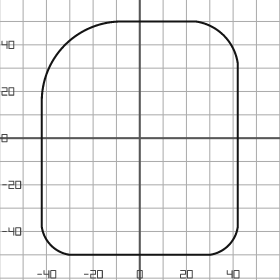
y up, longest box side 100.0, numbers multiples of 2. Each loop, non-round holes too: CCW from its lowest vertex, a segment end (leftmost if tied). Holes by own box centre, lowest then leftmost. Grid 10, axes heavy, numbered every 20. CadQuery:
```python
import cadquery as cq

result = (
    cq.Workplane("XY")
    .moveTo(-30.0, -50.0)
    .lineTo(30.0, -50.0)
    .threePointArc((38.0, -46.0), (42.0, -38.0))
    .lineTo(42.0, 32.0)
    .threePointArc((36.0, 44.0), (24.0, 50.0))
    .lineTo(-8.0, 50.0)
    .threePointArc((-32.0, 40.0), (-42.0, 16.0))
    .lineTo(-42.0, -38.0)
    .threePointArc((-38.0, -46.0), (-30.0, -50.0))
    .close()
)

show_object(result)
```